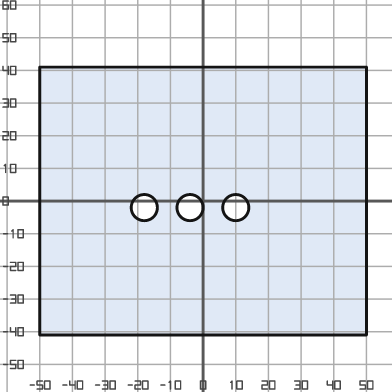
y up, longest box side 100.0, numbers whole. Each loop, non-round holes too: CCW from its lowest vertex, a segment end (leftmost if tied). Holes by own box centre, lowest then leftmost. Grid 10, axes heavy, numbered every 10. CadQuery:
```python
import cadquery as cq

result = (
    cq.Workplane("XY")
    .moveTo(-50.0, -41.0)
    .lineTo(50.0, -41.0)
    .lineTo(50.0, 41.0)
    .lineTo(-50.0, 41.0)
    .close()
    .moveTo(-18.0, -2.0)
    .circle(4.0)
    .moveTo(-4.0, -2.0)
    .circle(4.0)
    .moveTo(10.0, -2.0)
    .circle(4.0)
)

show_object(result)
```